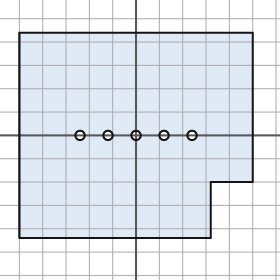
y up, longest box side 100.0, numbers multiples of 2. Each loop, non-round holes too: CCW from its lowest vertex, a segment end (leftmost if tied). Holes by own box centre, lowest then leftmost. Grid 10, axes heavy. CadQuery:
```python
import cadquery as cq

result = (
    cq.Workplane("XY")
    .moveTo(-50.0, -44.0)
    .lineTo(32.0, -44.0)
    .lineTo(32.0, -20.0)
    .lineTo(50.0, -20.0)
    .lineTo(50.0, 44.0)
    .lineTo(-50.0, 44.0)
    .close()
    .moveTo(-24.0, 0.0)
    .circle(2.0)
    .moveTo(-12.0, 0.0)
    .circle(2.0)
    .moveTo(0.0, 0.0)
    .circle(2.0)
    .moveTo(12.0, 0.0)
    .circle(2.0)
    .moveTo(24.0, 0.0)
    .circle(2.0)
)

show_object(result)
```